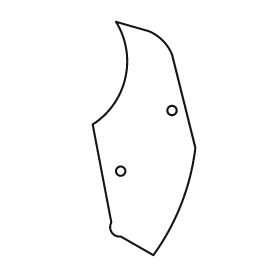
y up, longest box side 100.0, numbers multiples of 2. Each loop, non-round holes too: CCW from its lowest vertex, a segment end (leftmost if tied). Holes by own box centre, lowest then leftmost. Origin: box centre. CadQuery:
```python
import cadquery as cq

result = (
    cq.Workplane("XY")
    .moveTo(4.0, -50.0)
    .threePointArc((16.0, -28.0), (22.0, -4.0))
    .lineTo(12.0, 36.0)
    .threePointArc((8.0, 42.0), (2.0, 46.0))
    .lineTo(-12.0, 50.0)
    .threePointArc((-8.0, 26.0), (-22.0, 6.0))
    .lineTo(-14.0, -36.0)
    .threePointArc((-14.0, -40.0), (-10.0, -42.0))
    .close()
    .moveTo(-10.0, -14.0)
    .circle(2.0)
    .moveTo(12.0, 12.0)
    .circle(2.0)
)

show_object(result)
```